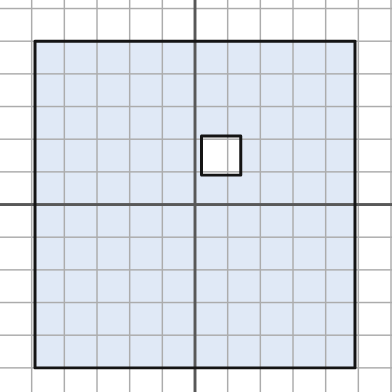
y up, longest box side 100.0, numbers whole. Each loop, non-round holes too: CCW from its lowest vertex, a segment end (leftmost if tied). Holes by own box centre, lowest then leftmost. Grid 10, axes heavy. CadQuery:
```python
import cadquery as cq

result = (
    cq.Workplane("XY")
    .moveTo(-49.0, -50.0)
    .lineTo(49.0, -50.0)
    .lineTo(49.0, 50.0)
    .lineTo(-49.0, 50.0)
    .close()
    .moveTo(2.0, 9.0)
    .lineTo(14.0, 9.0)
    .lineTo(14.0, 21.0)
    .lineTo(2.0, 21.0)
    .close()
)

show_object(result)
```